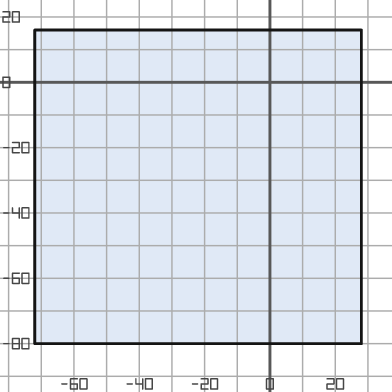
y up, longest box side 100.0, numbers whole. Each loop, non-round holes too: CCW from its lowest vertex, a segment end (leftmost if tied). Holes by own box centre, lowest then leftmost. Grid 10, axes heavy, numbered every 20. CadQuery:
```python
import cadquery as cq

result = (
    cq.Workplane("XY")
    .moveTo(-72.0, -80.0)
    .lineTo(28.0, -80.0)
    .lineTo(28.0, 16.0)
    .lineTo(-72.0, 16.0)
    .close()
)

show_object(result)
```